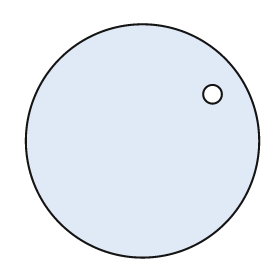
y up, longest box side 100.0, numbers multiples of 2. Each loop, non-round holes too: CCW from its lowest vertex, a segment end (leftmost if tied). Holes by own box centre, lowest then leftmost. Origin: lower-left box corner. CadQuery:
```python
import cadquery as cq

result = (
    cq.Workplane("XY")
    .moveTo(50.0, 50.0)
    .circle(50.0)
    .moveTo(80.0, 70.0)
    .circle(4.0)
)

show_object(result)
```